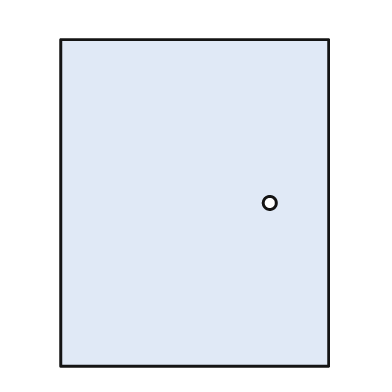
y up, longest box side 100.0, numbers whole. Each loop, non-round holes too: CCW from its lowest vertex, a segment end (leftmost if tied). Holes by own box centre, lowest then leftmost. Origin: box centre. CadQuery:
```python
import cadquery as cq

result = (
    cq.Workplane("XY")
    .moveTo(-41.0, -50.0)
    .lineTo(41.0, -50.0)
    .lineTo(41.0, 50.0)
    .lineTo(-41.0, 50.0)
    .close()
    .moveTo(23.0, 0.0)
    .circle(2.0)
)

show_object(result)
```